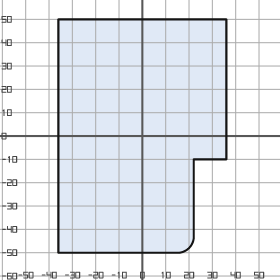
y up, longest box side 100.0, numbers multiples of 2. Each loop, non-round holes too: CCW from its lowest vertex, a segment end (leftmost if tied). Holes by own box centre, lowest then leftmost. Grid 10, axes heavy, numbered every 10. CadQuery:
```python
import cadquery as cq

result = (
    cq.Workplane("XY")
    .moveTo(-36.0, -50.0)
    .lineTo(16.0, -50.0)
    .threePointArc((20.0, -48.0), (22.0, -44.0))
    .lineTo(22.0, -10.0)
    .lineTo(36.0, -10.0)
    .lineTo(36.0, 50.0)
    .lineTo(-36.0, 50.0)
    .close()
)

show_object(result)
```